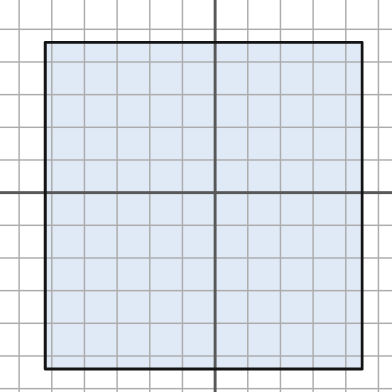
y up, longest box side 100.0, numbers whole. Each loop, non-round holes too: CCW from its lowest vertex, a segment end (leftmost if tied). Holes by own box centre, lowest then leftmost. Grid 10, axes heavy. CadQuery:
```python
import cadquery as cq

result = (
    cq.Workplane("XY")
    .moveTo(-52.0, -54.0)
    .lineTo(45.0, -54.0)
    .lineTo(45.0, 46.0)
    .lineTo(-52.0, 46.0)
    .close()
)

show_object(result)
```